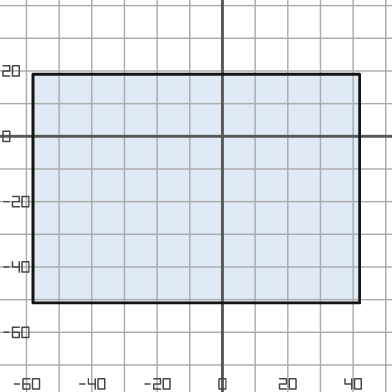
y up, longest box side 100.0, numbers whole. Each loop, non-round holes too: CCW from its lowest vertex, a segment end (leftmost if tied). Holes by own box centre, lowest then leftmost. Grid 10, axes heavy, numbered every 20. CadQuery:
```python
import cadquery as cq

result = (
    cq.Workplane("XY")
    .moveTo(-58.0, -51.0)
    .lineTo(42.0, -51.0)
    .lineTo(42.0, 19.0)
    .lineTo(-58.0, 19.0)
    .close()
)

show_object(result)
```